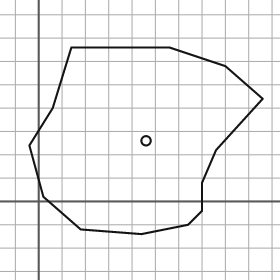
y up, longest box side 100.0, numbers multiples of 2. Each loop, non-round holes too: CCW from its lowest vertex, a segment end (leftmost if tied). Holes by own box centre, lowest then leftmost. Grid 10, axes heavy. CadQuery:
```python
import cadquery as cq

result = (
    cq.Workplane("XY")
    .moveTo(44.0, -14.0)
    .lineTo(64.0, -10.0)
    .lineTo(70.0, -4.0)
    .lineTo(70.0, 8.0)
    .lineTo(76.0, 22.0)
    .lineTo(96.0, 44.0)
    .lineTo(80.0, 58.0)
    .lineTo(56.0, 66.0)
    .lineTo(14.0, 66.0)
    .lineTo(6.0, 40.0)
    .lineTo(-4.0, 24.0)
    .lineTo(2.0, 2.0)
    .lineTo(18.0, -12.0)
    .close()
    .moveTo(46.0, 26.0)
    .circle(2.0)
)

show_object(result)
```